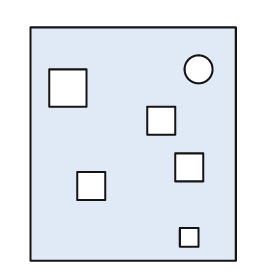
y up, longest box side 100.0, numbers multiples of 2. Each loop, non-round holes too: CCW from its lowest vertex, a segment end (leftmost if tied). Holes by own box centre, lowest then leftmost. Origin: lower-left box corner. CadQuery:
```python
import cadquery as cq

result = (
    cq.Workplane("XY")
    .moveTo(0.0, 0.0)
    .lineTo(88.0, 0.0)
    .lineTo(88.0, 100.0)
    .lineTo(0.0, 100.0)
    .close()
    .moveTo(64.0, 6.0)
    .lineTo(72.0, 6.0)
    .lineTo(72.0, 14.0)
    .lineTo(64.0, 14.0)
    .close()
    .moveTo(20.0, 26.0)
    .lineTo(32.0, 26.0)
    .lineTo(32.0, 38.0)
    .lineTo(20.0, 38.0)
    .close()
    .moveTo(62.0, 34.0)
    .lineTo(74.0, 34.0)
    .lineTo(74.0, 46.0)
    .lineTo(62.0, 46.0)
    .close()
    .moveTo(50.0, 54.0)
    .lineTo(62.0, 54.0)
    .lineTo(62.0, 66.0)
    .lineTo(50.0, 66.0)
    .close()
    .moveTo(8.0, 66.0)
    .lineTo(24.0, 66.0)
    .lineTo(24.0, 82.0)
    .lineTo(8.0, 82.0)
    .close()
    .moveTo(72.0, 82.0)
    .circle(6.0)
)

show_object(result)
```